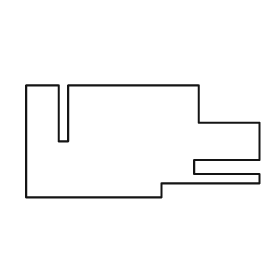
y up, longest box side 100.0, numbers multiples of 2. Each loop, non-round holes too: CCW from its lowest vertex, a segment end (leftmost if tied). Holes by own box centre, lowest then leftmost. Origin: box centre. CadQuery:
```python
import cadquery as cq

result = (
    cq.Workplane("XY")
    .moveTo(-50.0, -24.0)
    .lineTo(8.0, -24.0)
    .lineTo(8.0, -18.0)
    .lineTo(50.0, -18.0)
    .lineTo(50.0, -14.0)
    .lineTo(22.0, -14.0)
    .lineTo(22.0, -8.0)
    .lineTo(50.0, -8.0)
    .lineTo(50.0, 8.0)
    .lineTo(24.0, 8.0)
    .lineTo(24.0, 24.0)
    .lineTo(-32.0, 24.0)
    .lineTo(-32.0, 0.0)
    .lineTo(-36.0, 0.0)
    .lineTo(-36.0, 24.0)
    .lineTo(-50.0, 24.0)
    .close()
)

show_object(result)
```